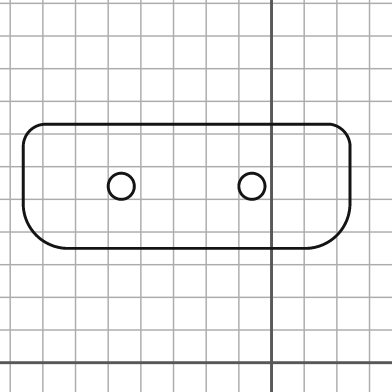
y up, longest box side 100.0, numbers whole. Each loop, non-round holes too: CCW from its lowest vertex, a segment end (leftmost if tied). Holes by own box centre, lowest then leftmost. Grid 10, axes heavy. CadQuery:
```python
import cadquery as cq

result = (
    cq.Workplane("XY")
    .moveTo(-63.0, 35.0)
    .lineTo(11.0, 35.0)
    .threePointArc((20.0, 39.0), (24.0, 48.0))
    .lineTo(24.0, 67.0)
    .threePointArc((22.0, 71.0), (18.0, 73.0))
    .lineTo(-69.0, 73.0)
    .threePointArc((-74.0, 71.0), (-76.0, 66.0))
    .lineTo(-76.0, 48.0)
    .threePointArc((-72.0, 39.0), (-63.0, 35.0))
    .close()
    .moveTo(-46.0, 54.0)
    .circle(4.0)
    .moveTo(-6.0, 54.0)
    .circle(4.0)
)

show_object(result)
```